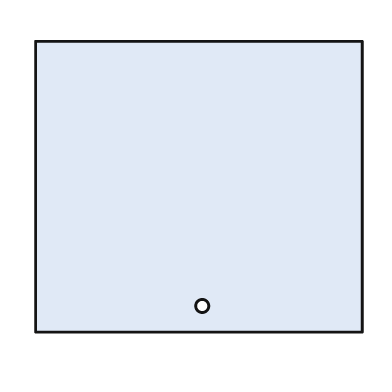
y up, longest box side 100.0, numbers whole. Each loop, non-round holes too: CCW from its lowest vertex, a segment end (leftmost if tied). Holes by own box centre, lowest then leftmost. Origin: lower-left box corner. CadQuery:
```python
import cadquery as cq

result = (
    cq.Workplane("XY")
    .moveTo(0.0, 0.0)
    .lineTo(100.0, 0.0)
    .lineTo(100.0, 89.0)
    .lineTo(0.0, 89.0)
    .close()
    .moveTo(51.0, 8.0)
    .circle(2.0)
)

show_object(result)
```